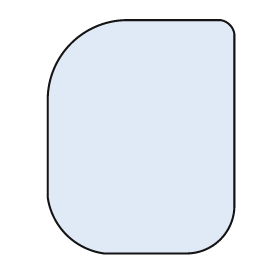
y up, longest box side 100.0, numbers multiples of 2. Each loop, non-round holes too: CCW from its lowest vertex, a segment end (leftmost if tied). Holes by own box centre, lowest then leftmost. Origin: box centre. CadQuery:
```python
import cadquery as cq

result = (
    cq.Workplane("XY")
    .moveTo(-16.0, -50.0)
    .lineTo(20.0, -50.0)
    .threePointArc((34.0, -44.0), (40.0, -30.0))
    .lineTo(40.0, 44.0)
    .threePointArc((38.0, 48.0), (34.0, 50.0))
    .lineTo(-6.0, 50.0)
    .threePointArc((-30.0, 40.0), (-40.0, 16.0))
    .lineTo(-40.0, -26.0)
    .threePointArc((-32.0, -42.0), (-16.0, -50.0))
    .close()
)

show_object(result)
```